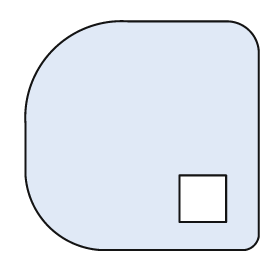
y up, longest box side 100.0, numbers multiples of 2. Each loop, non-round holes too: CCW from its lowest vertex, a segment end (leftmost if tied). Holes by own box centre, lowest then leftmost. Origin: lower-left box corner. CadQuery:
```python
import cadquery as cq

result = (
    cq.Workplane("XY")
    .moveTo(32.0, 0.0)
    .lineTo(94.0, 0.0)
    .threePointArc((98.0, 2.0), (100.0, 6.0))
    .lineTo(100.0, 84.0)
    .threePointArc((96.0, 94.0), (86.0, 98.0))
    .lineTo(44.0, 98.0)
    .threePointArc((12.0, 86.0), (0.0, 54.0))
    .lineTo(0.0, 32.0)
    .threePointArc((10.0, 10.0), (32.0, 0.0))
    .close()
    .moveTo(66.0, 12.0)
    .lineTo(86.0, 12.0)
    .lineTo(86.0, 32.0)
    .lineTo(66.0, 32.0)
    .close()
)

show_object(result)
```